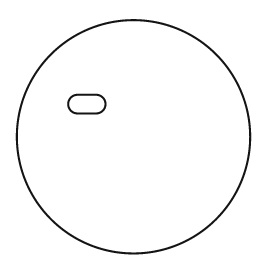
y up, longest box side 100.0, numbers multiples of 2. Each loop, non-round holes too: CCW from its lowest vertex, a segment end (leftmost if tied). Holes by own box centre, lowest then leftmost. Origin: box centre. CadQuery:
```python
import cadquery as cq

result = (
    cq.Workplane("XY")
    .moveTo(0.0, 0.0)
    .circle(50.0)
    .moveTo(-24.0, 10.0)
    .lineTo(-16.0, 10.0)
    .threePointArc((-12.0, 14.0), (-16.0, 18.0))
    .lineTo(-24.0, 18.0)
    .threePointArc((-28.0, 14.0), (-24.0, 10.0))
    .close()
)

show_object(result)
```